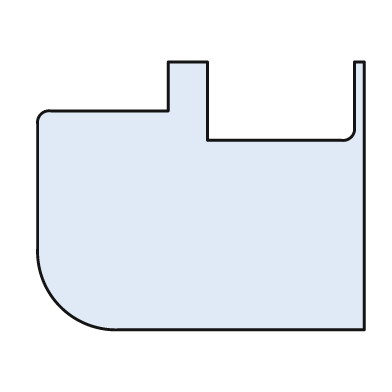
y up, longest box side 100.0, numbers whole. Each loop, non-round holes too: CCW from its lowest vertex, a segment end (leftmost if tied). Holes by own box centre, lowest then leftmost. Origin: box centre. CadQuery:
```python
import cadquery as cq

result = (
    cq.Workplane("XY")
    .moveTo(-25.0, -41.0)
    .lineTo(50.0, -41.0)
    .lineTo(50.0, 41.0)
    .lineTo(47.0, 41.0)
    .lineTo(47.0, 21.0)
    .threePointArc((46.0, 18.0), (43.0, 17.0))
    .lineTo(2.0, 17.0)
    .lineTo(2.0, 41.0)
    .lineTo(-10.0, 41.0)
    .lineTo(-10.0, 26.0)
    .lineTo(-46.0, 26.0)
    .threePointArc((-49.0, 25.0), (-50.0, 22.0))
    .lineTo(-50.0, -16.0)
    .threePointArc((-43.0, -34.0), (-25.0, -41.0))
    .close()
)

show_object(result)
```